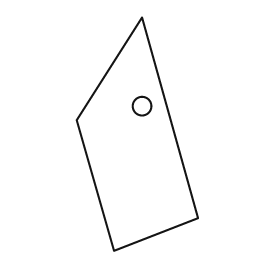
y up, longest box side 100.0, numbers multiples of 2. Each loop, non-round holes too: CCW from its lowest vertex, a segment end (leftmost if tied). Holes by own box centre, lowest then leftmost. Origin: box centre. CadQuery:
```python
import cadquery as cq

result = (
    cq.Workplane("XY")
    .moveTo(-10.0, -50.0)
    .lineTo(26.0, -36.0)
    .lineTo(2.0, 50.0)
    .lineTo(-26.0, 6.0)
    .close()
    .moveTo(2.0, 12.0)
    .circle(4.0)
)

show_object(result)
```